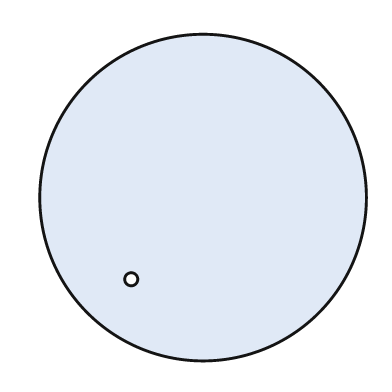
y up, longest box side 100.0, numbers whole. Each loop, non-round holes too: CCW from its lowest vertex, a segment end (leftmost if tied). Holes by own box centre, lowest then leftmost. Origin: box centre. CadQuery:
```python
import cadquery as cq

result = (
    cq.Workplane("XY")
    .moveTo(0.0, 0.0)
    .circle(50.0)
    .moveTo(-22.0, -25.0)
    .circle(2.0)
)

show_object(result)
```